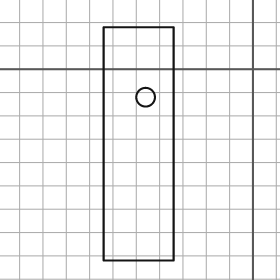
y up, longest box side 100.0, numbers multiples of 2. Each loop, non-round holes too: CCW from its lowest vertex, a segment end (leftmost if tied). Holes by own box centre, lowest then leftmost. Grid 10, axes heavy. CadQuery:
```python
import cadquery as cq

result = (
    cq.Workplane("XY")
    .moveTo(-64.0, -82.0)
    .lineTo(-34.0, -82.0)
    .lineTo(-34.0, 18.0)
    .lineTo(-64.0, 18.0)
    .close()
    .moveTo(-46.0, -12.0)
    .circle(4.0)
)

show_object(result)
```